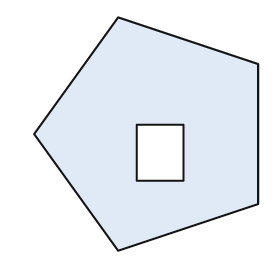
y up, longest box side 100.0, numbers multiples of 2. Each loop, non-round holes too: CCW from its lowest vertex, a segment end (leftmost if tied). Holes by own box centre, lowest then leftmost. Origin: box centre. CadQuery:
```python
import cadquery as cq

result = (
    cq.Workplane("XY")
    .moveTo(-12.0, -50.0)
    .lineTo(48.0, -30.0)
    .lineTo(48.0, 30.0)
    .lineTo(-12.0, 50.0)
    .lineTo(-48.0, 0.0)
    .close()
    .moveTo(-4.0, -20.0)
    .lineTo(16.0, -20.0)
    .lineTo(16.0, 4.0)
    .lineTo(-4.0, 4.0)
    .close()
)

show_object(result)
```